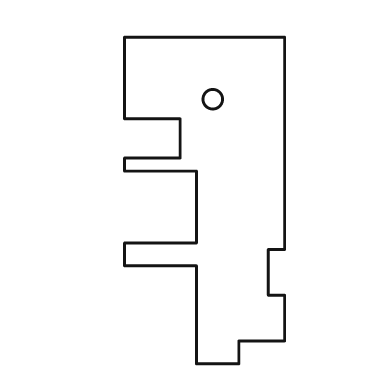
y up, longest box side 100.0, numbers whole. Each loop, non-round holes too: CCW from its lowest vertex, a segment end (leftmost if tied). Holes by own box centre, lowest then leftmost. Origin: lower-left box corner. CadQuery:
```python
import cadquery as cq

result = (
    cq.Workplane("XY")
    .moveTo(22.0, 0.0)
    .lineTo(35.0, 0.0)
    .lineTo(35.0, 7.0)
    .lineTo(49.0, 7.0)
    .lineTo(49.0, 21.0)
    .lineTo(44.0, 21.0)
    .lineTo(44.0, 35.0)
    .lineTo(49.0, 35.0)
    .lineTo(49.0, 100.0)
    .lineTo(0.0, 100.0)
    .lineTo(0.0, 75.0)
    .lineTo(17.0, 75.0)
    .lineTo(17.0, 63.0)
    .lineTo(0.0, 63.0)
    .lineTo(0.0, 59.0)
    .lineTo(22.0, 59.0)
    .lineTo(22.0, 37.0)
    .lineTo(0.0, 37.0)
    .lineTo(0.0, 30.0)
    .lineTo(22.0, 30.0)
    .close()
    .moveTo(27.0, 81.0)
    .circle(3.0)
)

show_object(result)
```